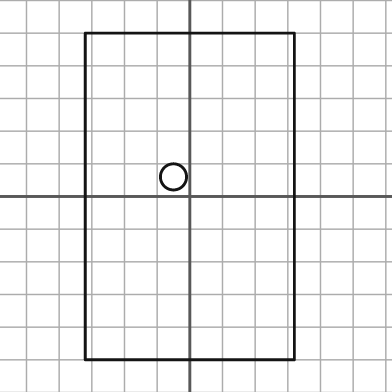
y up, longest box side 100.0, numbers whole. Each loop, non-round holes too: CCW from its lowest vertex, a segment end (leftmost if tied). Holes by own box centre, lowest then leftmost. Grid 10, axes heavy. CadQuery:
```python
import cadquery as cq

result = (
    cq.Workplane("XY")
    .moveTo(-32.0, -50.0)
    .lineTo(32.0, -50.0)
    .lineTo(32.0, 50.0)
    .lineTo(-32.0, 50.0)
    .close()
    .moveTo(-5.0, 6.0)
    .circle(4.0)
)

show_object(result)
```